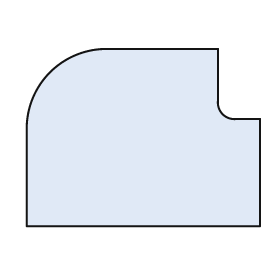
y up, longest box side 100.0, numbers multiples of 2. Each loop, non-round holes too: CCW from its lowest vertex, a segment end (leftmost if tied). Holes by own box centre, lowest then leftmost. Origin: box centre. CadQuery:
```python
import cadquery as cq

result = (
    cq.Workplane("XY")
    .moveTo(-50.0, -38.0)
    .lineTo(50.0, -38.0)
    .lineTo(50.0, 8.0)
    .lineTo(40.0, 8.0)
    .threePointArc((34.0, 10.0), (32.0, 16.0))
    .lineTo(32.0, 38.0)
    .lineTo(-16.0, 38.0)
    .threePointArc((-40.0, 28.0), (-50.0, 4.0))
    .close()
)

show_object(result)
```